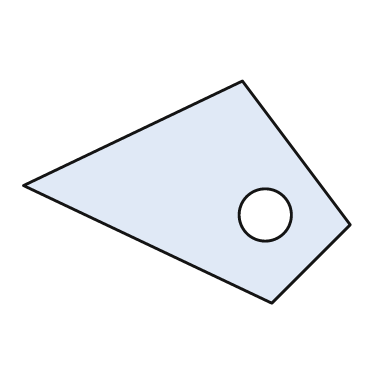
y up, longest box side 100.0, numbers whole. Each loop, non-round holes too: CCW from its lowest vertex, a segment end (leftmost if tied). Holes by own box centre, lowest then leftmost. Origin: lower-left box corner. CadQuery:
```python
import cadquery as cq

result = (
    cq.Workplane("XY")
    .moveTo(76.0, 0.0)
    .lineTo(100.0, 24.0)
    .lineTo(67.0, 68.0)
    .lineTo(0.0, 36.0)
    .close()
    .moveTo(74.0, 27.0)
    .circle(8.0)
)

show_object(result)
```